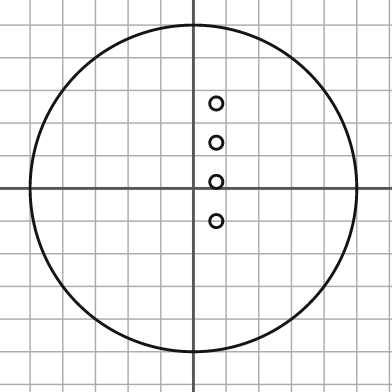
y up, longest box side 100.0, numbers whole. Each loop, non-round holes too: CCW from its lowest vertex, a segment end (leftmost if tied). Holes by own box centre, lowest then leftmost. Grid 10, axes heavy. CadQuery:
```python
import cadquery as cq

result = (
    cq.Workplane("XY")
    .moveTo(0.0, 0.0)
    .circle(50.0)
    .moveTo(7.0, -10.0)
    .circle(2.0)
    .moveTo(7.0, 2.0)
    .circle(2.0)
    .moveTo(7.0, 14.0)
    .circle(2.0)
    .moveTo(7.0, 26.0)
    .circle(2.0)
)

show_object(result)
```